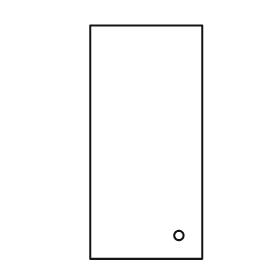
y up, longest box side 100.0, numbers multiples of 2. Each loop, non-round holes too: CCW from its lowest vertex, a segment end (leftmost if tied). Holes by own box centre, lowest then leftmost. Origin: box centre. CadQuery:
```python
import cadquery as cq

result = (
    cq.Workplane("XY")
    .moveTo(-24.0, -50.0)
    .lineTo(24.0, -50.0)
    .lineTo(24.0, 50.0)
    .lineTo(-24.0, 50.0)
    .close()
    .moveTo(14.0, -40.0)
    .circle(2.0)
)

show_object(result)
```